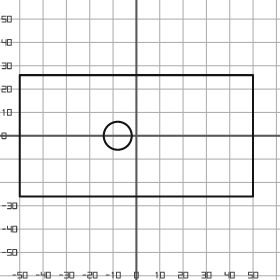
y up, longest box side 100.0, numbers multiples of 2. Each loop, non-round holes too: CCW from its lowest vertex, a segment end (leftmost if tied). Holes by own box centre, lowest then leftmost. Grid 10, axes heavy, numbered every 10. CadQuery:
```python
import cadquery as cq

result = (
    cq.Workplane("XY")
    .moveTo(-50.0, -26.0)
    .lineTo(50.0, -26.0)
    .lineTo(50.0, 26.0)
    .lineTo(-50.0, 26.0)
    .close()
    .moveTo(-8.0, 0.0)
    .circle(6.0)
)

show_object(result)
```